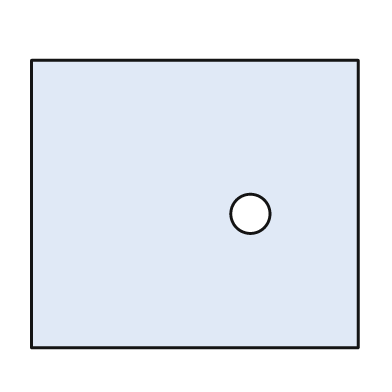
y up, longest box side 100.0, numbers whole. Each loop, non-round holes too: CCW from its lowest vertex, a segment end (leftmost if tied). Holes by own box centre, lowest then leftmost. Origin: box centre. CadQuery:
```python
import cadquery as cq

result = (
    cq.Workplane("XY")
    .moveTo(-50.0, -44.0)
    .lineTo(50.0, -44.0)
    .lineTo(50.0, 44.0)
    .lineTo(-50.0, 44.0)
    .close()
    .moveTo(17.0, -3.0)
    .circle(6.0)
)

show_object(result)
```